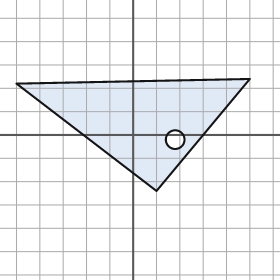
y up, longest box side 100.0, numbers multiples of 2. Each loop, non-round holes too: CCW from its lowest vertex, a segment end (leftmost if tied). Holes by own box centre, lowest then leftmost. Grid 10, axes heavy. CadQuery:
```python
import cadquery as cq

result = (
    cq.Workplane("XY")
    .moveTo(10.0, -24.0)
    .lineTo(50.0, 24.0)
    .lineTo(-50.0, 22.0)
    .close()
    .moveTo(18.0, -2.0)
    .circle(4.0)
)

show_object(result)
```